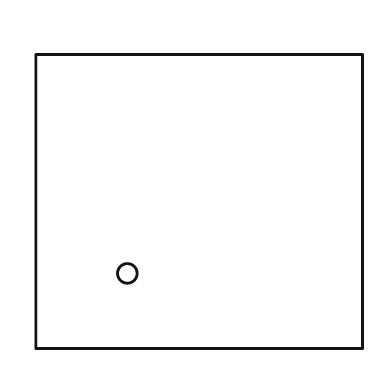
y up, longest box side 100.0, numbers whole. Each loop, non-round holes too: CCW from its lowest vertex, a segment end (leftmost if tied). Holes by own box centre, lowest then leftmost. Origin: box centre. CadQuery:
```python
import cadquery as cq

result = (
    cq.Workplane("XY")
    .moveTo(-50.0, -45.0)
    .lineTo(50.0, -45.0)
    .lineTo(50.0, 45.0)
    .lineTo(-50.0, 45.0)
    .close()
    .moveTo(-22.0, -22.0)
    .circle(3.0)
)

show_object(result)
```